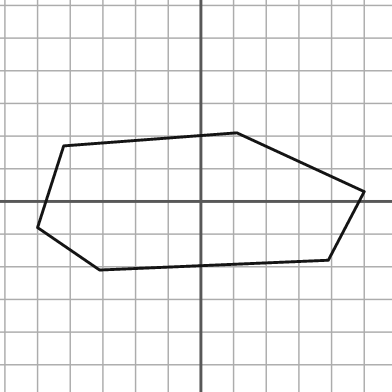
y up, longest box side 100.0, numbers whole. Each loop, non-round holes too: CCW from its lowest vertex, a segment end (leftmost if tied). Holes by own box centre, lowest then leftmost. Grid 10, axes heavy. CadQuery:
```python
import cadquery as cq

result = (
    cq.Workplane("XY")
    .moveTo(-31.0, -21.0)
    .lineTo(39.0, -18.0)
    .lineTo(50.0, 3.0)
    .lineTo(11.0, 21.0)
    .lineTo(-42.0, 17.0)
    .lineTo(-50.0, -8.0)
    .close()
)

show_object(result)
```